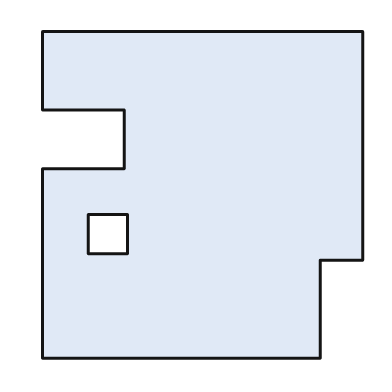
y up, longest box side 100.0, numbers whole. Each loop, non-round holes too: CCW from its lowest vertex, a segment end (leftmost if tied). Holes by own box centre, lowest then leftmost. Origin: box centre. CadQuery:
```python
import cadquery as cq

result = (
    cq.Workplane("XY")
    .moveTo(-49.0, -50.0)
    .lineTo(36.0, -50.0)
    .lineTo(36.0, -20.0)
    .lineTo(49.0, -20.0)
    .lineTo(49.0, 50.0)
    .lineTo(-49.0, 50.0)
    .lineTo(-49.0, 26.0)
    .lineTo(-24.0, 26.0)
    .lineTo(-24.0, 8.0)
    .lineTo(-49.0, 8.0)
    .close()
    .moveTo(-35.0, -18.0)
    .lineTo(-23.0, -18.0)
    .lineTo(-23.0, -6.0)
    .lineTo(-35.0, -6.0)
    .close()
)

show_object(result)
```